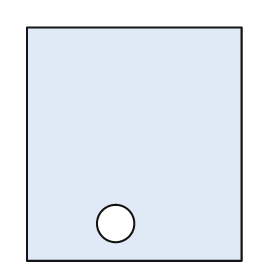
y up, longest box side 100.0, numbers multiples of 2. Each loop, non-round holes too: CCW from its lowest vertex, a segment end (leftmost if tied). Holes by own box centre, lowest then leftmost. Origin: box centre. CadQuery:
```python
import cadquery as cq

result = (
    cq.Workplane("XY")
    .moveTo(-46.0, -50.0)
    .lineTo(46.0, -50.0)
    .lineTo(46.0, 50.0)
    .lineTo(-46.0, 50.0)
    .close()
    .moveTo(-8.0, -34.0)
    .circle(8.0)
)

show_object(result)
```